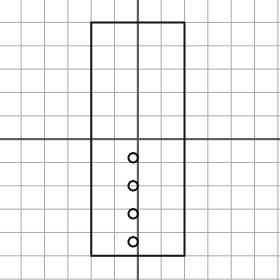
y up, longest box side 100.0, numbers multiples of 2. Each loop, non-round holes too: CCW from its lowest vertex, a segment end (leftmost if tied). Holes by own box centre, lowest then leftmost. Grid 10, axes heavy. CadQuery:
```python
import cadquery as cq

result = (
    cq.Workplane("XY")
    .moveTo(-20.0, -50.0)
    .lineTo(20.0, -50.0)
    .lineTo(20.0, 50.0)
    .lineTo(-20.0, 50.0)
    .close()
    .moveTo(-2.0, -44.0)
    .circle(2.0)
    .moveTo(-2.0, -32.0)
    .circle(2.0)
    .moveTo(-2.0, -20.0)
    .circle(2.0)
    .moveTo(-2.0, -8.0)
    .circle(2.0)
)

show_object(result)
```